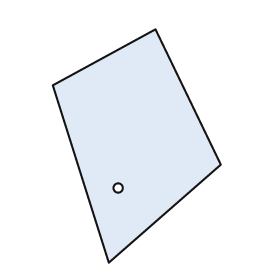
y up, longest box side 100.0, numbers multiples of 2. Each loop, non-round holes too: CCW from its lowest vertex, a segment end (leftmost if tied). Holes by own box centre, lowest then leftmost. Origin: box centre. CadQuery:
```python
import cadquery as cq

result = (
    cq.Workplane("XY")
    .moveTo(-12.0, -50.0)
    .lineTo(36.0, -8.0)
    .lineTo(8.0, 50.0)
    .lineTo(-36.0, 26.0)
    .close()
    .moveTo(-8.0, -18.0)
    .circle(2.0)
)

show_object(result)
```